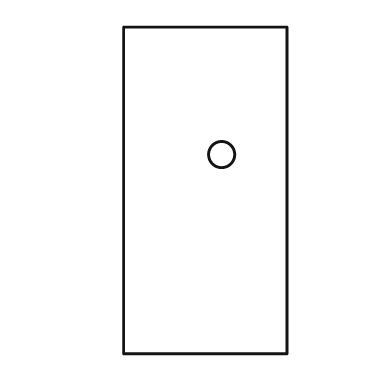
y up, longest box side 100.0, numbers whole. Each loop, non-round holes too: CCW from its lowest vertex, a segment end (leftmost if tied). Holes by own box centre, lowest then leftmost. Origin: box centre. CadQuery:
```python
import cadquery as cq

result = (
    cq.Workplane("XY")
    .moveTo(-25.0, -50.0)
    .lineTo(25.0, -50.0)
    .lineTo(25.0, 50.0)
    .lineTo(-25.0, 50.0)
    .close()
    .moveTo(5.0, 11.0)
    .circle(4.0)
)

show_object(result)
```